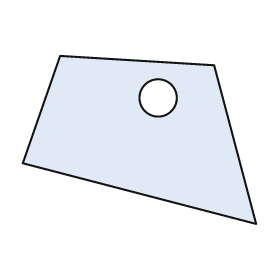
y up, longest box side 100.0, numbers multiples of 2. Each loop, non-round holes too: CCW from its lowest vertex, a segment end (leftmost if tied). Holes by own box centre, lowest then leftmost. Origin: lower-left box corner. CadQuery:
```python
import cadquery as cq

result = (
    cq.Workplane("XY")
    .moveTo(100.0, 0.0)
    .lineTo(82.0, 68.0)
    .lineTo(16.0, 72.0)
    .lineTo(0.0, 26.0)
    .close()
    .moveTo(58.0, 54.0)
    .circle(8.0)
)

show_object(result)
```